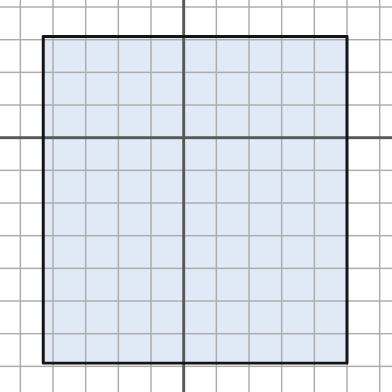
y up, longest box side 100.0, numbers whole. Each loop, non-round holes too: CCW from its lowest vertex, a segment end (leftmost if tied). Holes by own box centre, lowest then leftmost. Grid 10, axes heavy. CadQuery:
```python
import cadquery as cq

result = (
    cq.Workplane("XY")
    .moveTo(-43.0, -69.0)
    .lineTo(50.0, -69.0)
    .lineTo(50.0, 31.0)
    .lineTo(-43.0, 31.0)
    .close()
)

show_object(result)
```